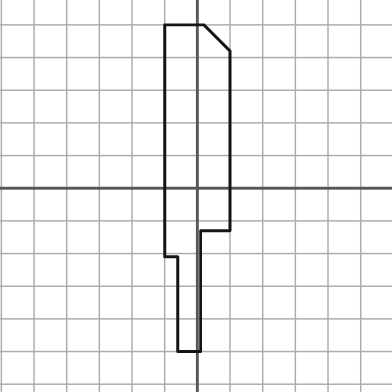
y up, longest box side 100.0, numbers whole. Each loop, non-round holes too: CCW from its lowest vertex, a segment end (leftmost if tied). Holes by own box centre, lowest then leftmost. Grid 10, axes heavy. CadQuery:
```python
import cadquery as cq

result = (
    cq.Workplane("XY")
    .moveTo(-6.0, -50.0)
    .lineTo(1.0, -50.0)
    .lineTo(1.0, -13.0)
    .lineTo(10.0, -13.0)
    .lineTo(10.0, 42.0)
    .lineTo(2.0, 50.0)
    .lineTo(-10.0, 50.0)
    .lineTo(-10.0, -21.0)
    .lineTo(-6.0, -21.0)
    .close()
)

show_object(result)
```